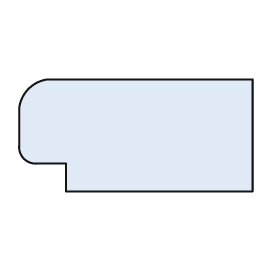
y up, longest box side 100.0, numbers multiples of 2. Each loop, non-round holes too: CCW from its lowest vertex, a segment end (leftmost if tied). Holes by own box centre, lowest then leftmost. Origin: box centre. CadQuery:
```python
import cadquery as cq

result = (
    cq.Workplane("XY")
    .moveTo(-30.0, -24.0)
    .lineTo(50.0, -24.0)
    .lineTo(50.0, 24.0)
    .lineTo(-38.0, 24.0)
    .threePointArc((-46.0, 20.0), (-50.0, 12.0))
    .lineTo(-50.0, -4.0)
    .threePointArc((-48.0, -10.0), (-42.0, -12.0))
    .lineTo(-30.0, -12.0)
    .close()
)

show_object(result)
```